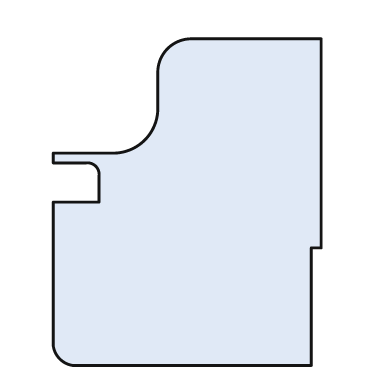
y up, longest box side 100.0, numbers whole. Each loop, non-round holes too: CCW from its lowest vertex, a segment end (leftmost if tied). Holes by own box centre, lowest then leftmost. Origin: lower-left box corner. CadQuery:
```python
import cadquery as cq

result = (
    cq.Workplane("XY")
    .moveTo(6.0, 0.0)
    .lineTo(79.0, 0.0)
    .lineTo(79.0, 36.0)
    .lineTo(82.0, 36.0)
    .lineTo(82.0, 100.0)
    .lineTo(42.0, 100.0)
    .threePointArc((35.0, 97.0), (32.0, 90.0))
    .lineTo(32.0, 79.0)
    .threePointArc((28.0, 69.0), (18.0, 65.0))
    .lineTo(0.0, 65.0)
    .lineTo(0.0, 62.0)
    .lineTo(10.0, 62.0)
    .threePointArc((13.0, 61.0), (14.0, 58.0))
    .lineTo(14.0, 50.0)
    .lineTo(0.0, 50.0)
    .lineTo(0.0, 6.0)
    .threePointArc((2.0, 2.0), (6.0, 0.0))
    .close()
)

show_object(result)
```